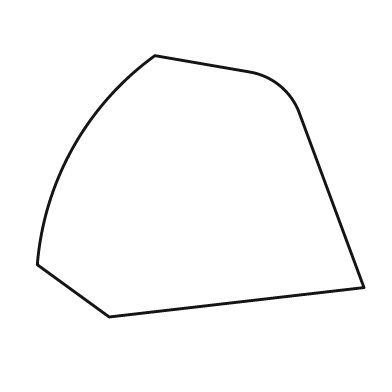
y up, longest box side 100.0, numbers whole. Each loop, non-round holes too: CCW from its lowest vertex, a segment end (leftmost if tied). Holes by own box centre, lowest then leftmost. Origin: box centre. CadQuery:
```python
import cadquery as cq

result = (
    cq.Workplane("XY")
    .moveTo(-28.0, -40.0)
    .lineTo(50.0, -31.0)
    .lineTo(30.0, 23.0)
    .threePointArc((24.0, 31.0), (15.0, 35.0))
    .lineTo(-14.0, 40.0)
    .threePointArc((-39.0, 12.0), (-50.0, -24.0))
    .close()
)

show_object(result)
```